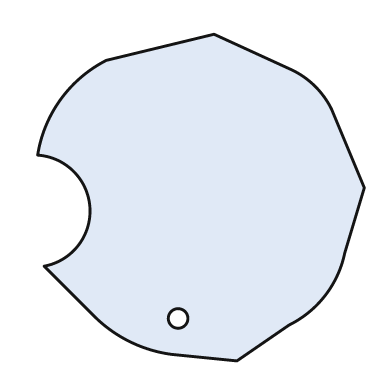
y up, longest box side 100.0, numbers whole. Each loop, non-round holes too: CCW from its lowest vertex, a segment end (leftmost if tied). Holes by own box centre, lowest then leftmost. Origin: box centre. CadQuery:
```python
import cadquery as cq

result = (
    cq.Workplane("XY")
    .moveTo(11.0, -50.0)
    .lineTo(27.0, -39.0)
    .threePointArc((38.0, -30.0), (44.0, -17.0))
    .lineTo(50.0, 3.0)
    .lineTo(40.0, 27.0)
    .threePointArc((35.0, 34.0), (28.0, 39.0))
    .lineTo(4.0, 50.0)
    .lineTo(-29.0, 42.0)
    .threePointArc((-43.0, 30.0), (-50.0, 13.0))
    .threePointArc((-34.0, -3.0), (-48.0, -21.0))
    .lineTo(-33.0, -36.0)
    .threePointArc((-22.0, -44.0), (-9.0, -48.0))
    .close()
    .moveTo(-7.0, -37.0)
    .circle(3.0)
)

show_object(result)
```